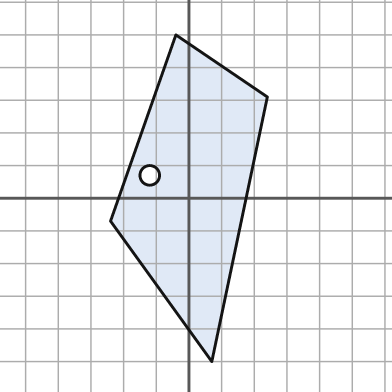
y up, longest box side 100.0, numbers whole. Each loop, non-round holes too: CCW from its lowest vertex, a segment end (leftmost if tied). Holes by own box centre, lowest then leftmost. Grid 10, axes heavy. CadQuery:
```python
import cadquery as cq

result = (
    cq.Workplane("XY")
    .moveTo(7.0, -50.0)
    .lineTo(24.0, 31.0)
    .lineTo(-4.0, 50.0)
    .lineTo(-24.0, -7.0)
    .close()
    .moveTo(-12.0, 7.0)
    .circle(3.0)
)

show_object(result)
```